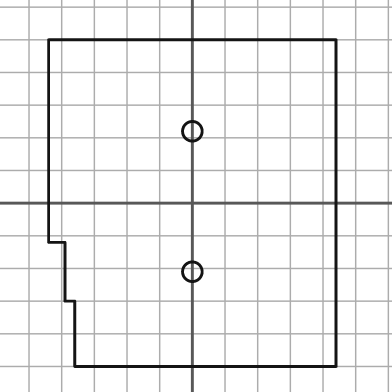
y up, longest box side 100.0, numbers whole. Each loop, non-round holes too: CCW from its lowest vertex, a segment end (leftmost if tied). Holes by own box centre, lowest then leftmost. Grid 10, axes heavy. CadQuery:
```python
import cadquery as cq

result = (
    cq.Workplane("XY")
    .moveTo(-36.0, -50.0)
    .lineTo(44.0, -50.0)
    .lineTo(44.0, 50.0)
    .lineTo(-44.0, 50.0)
    .lineTo(-44.0, -12.0)
    .lineTo(-39.0, -12.0)
    .lineTo(-39.0, -30.0)
    .lineTo(-36.0, -30.0)
    .close()
    .moveTo(0.0, -21.0)
    .circle(3.0)
    .moveTo(0.0, 22.0)
    .circle(3.0)
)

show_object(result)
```